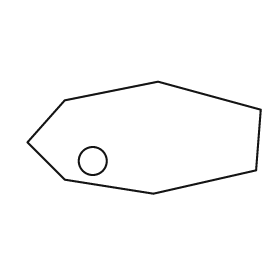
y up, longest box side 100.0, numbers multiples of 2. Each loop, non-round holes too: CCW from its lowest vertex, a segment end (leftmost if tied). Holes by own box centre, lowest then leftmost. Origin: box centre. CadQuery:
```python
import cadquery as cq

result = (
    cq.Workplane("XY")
    .moveTo(4.0, -24.0)
    .lineTo(48.0, -14.0)
    .lineTo(50.0, 12.0)
    .lineTo(6.0, 24.0)
    .lineTo(-34.0, 16.0)
    .lineTo(-50.0, -2.0)
    .lineTo(-34.0, -18.0)
    .close()
    .moveTo(-22.0, -10.0)
    .circle(6.0)
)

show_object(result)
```